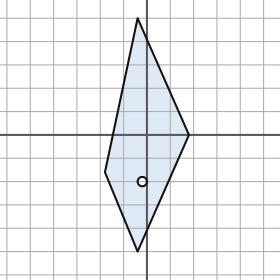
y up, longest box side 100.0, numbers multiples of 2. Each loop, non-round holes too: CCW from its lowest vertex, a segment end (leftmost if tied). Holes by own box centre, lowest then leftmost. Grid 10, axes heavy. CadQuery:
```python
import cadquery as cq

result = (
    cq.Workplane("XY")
    .moveTo(-4.0, -50.0)
    .lineTo(18.0, 0.0)
    .lineTo(-4.0, 50.0)
    .lineTo(-18.0, -16.0)
    .close()
    .moveTo(-2.0, -20.0)
    .circle(2.0)
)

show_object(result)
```